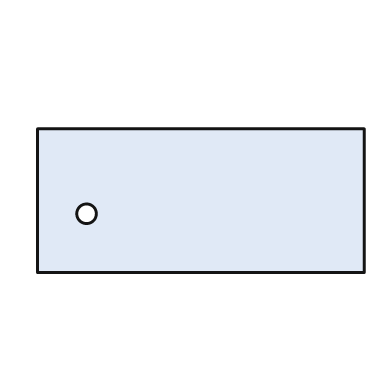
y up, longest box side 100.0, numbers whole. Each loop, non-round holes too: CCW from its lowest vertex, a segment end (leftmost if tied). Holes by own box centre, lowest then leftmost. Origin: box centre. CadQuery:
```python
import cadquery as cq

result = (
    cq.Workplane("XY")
    .moveTo(-50.0, -22.0)
    .lineTo(50.0, -22.0)
    .lineTo(50.0, 22.0)
    .lineTo(-50.0, 22.0)
    .close()
    .moveTo(-35.0, -4.0)
    .circle(3.0)
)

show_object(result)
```